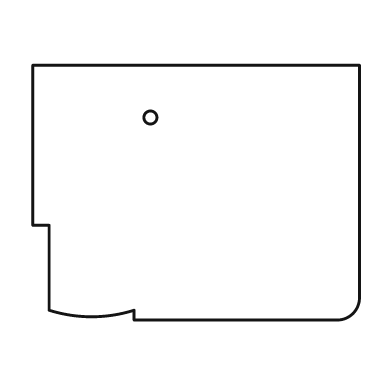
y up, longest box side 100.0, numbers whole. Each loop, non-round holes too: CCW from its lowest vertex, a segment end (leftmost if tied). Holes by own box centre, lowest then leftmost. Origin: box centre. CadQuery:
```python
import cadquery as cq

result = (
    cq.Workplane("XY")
    .moveTo(-19.0, -39.0)
    .lineTo(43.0, -39.0)
    .threePointArc((48.0, -37.0), (50.0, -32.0))
    .lineTo(50.0, 39.0)
    .lineTo(-50.0, 39.0)
    .lineTo(-50.0, -10.0)
    .lineTo(-45.0, -10.0)
    .lineTo(-45.0, -36.0)
    .threePointArc((-32.0, -38.0), (-19.0, -36.0))
    .close()
    .moveTo(-14.0, 23.0)
    .circle(2.0)
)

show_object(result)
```